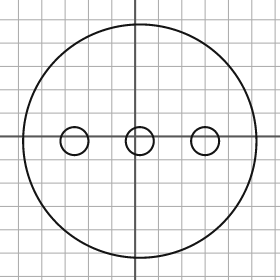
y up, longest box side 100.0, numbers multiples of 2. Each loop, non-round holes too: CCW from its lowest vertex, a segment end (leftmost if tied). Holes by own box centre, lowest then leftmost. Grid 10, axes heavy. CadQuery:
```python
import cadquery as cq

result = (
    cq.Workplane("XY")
    .moveTo(2.0, -2.0)
    .circle(50.0)
    .moveTo(-26.0, -2.0)
    .circle(6.0)
    .moveTo(2.0, -2.0)
    .circle(6.0)
    .moveTo(30.0, -2.0)
    .circle(6.0)
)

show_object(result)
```